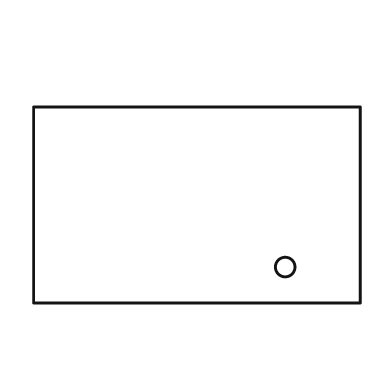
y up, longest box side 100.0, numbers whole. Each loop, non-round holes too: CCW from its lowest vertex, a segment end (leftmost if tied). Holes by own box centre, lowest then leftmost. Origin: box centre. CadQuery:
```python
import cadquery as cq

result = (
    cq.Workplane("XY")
    .moveTo(-50.0, -30.0)
    .lineTo(50.0, -30.0)
    .lineTo(50.0, 30.0)
    .lineTo(-50.0, 30.0)
    .close()
    .moveTo(27.0, -19.0)
    .circle(3.0)
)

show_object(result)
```